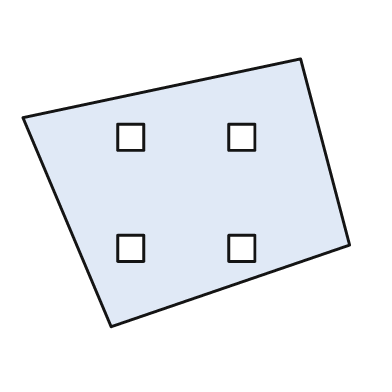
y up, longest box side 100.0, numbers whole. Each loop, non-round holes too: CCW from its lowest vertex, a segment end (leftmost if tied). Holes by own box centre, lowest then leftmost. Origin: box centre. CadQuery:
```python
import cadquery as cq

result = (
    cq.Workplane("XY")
    .moveTo(-23.0, -41.0)
    .lineTo(50.0, -16.0)
    .lineTo(35.0, 41.0)
    .lineTo(-50.0, 23.0)
    .close()
    .moveTo(-21.0, -21.0)
    .lineTo(-13.0, -21.0)
    .lineTo(-13.0, -13.0)
    .lineTo(-21.0, -13.0)
    .close()
    .moveTo(13.0, -21.0)
    .lineTo(21.0, -21.0)
    .lineTo(21.0, -13.0)
    .lineTo(13.0, -13.0)
    .close()
    .moveTo(-21.0, 13.0)
    .lineTo(-13.0, 13.0)
    .lineTo(-13.0, 21.0)
    .lineTo(-21.0, 21.0)
    .close()
    .moveTo(13.0, 13.0)
    .lineTo(21.0, 13.0)
    .lineTo(21.0, 21.0)
    .lineTo(13.0, 21.0)
    .close()
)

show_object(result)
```